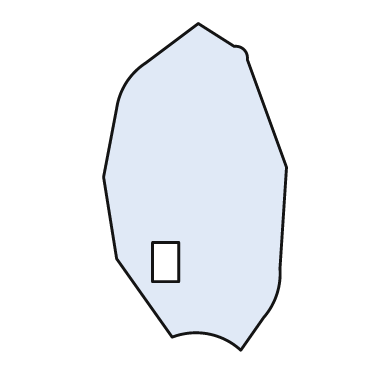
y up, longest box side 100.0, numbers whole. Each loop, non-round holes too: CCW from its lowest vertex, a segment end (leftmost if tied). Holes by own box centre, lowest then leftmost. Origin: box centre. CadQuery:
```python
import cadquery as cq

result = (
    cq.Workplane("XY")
    .moveTo(14.0, -50.0)
    .lineTo(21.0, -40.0)
    .threePointArc((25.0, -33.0), (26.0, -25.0))
    .lineTo(28.0, 6.0)
    .lineTo(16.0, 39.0)
    .threePointArc((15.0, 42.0), (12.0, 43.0))
    .lineTo(1.0, 50.0)
    .lineTo(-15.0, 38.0)
    .threePointArc((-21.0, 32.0), (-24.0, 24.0))
    .lineTo(-28.0, 3.0)
    .lineTo(-24.0, -22.0)
    .lineTo(-7.0, -46.0)
    .threePointArc((4.0, -45.0), (14.0, -50.0))
    .close()
    .moveTo(-13.0, -29.0)
    .lineTo(-5.0, -29.0)
    .lineTo(-5.0, -17.0)
    .lineTo(-13.0, -17.0)
    .close()
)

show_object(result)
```